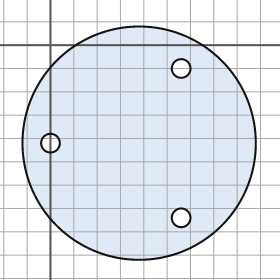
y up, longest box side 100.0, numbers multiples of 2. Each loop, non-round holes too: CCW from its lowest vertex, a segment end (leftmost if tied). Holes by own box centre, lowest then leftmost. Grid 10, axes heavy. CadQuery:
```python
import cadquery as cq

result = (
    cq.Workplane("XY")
    .moveTo(38.0, -42.0)
    .circle(50.0)
    .moveTo(56.0, -74.0)
    .circle(4.0)
    .moveTo(0.0, -42.0)
    .circle(4.0)
    .moveTo(56.0, -10.0)
    .circle(4.0)
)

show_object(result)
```